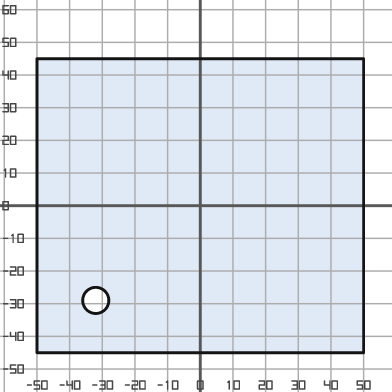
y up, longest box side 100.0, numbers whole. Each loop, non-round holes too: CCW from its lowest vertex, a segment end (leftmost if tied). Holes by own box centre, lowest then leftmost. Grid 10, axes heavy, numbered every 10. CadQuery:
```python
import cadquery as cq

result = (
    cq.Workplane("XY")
    .moveTo(-50.0, -45.0)
    .lineTo(50.0, -45.0)
    .lineTo(50.0, 45.0)
    .lineTo(-50.0, 45.0)
    .close()
    .moveTo(-32.0, -29.0)
    .circle(4.0)
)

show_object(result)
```